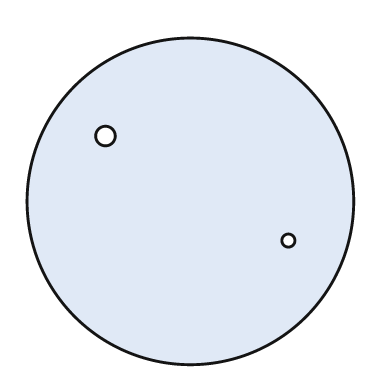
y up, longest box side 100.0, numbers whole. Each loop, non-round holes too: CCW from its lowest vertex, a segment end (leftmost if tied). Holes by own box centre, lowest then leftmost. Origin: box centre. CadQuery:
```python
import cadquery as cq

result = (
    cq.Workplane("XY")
    .moveTo(0.0, 0.0)
    .circle(50.0)
    .moveTo(30.0, -12.0)
    .circle(2.0)
    .moveTo(-26.0, 20.0)
    .circle(3.0)
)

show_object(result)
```